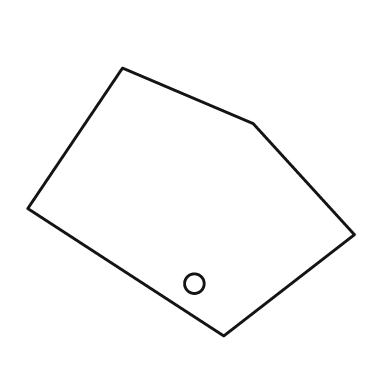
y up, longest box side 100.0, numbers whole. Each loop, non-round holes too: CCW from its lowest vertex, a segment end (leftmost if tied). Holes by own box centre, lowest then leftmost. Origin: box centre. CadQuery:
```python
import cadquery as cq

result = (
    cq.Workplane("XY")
    .moveTo(10.0, -41.0)
    .lineTo(50.0, -10.0)
    .lineTo(19.0, 24.0)
    .lineTo(-21.0, 41.0)
    .lineTo(-50.0, -2.0)
    .close()
    .moveTo(1.0, -25.0)
    .circle(3.0)
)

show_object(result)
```